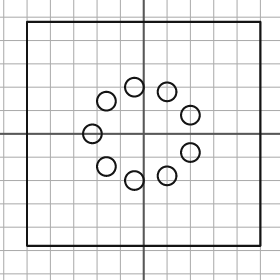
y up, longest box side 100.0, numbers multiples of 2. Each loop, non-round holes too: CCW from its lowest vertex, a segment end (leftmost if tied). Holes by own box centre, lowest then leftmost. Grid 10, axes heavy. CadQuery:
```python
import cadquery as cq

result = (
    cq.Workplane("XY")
    .moveTo(-50.0, -48.0)
    .lineTo(50.0, -48.0)
    .lineTo(50.0, 48.0)
    .lineTo(-50.0, 48.0)
    .close()
    .moveTo(-4.0, -20.0)
    .circle(4.0)
    .moveTo(10.0, -18.0)
    .circle(4.0)
    .moveTo(-16.0, -14.0)
    .circle(4.0)
    .moveTo(20.0, -8.0)
    .circle(4.0)
    .moveTo(-22.0, 0.0)
    .circle(4.0)
    .moveTo(20.0, 8.0)
    .circle(4.0)
    .moveTo(-16.0, 14.0)
    .circle(4.0)
    .moveTo(10.0, 18.0)
    .circle(4.0)
    .moveTo(-4.0, 20.0)
    .circle(4.0)
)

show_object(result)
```